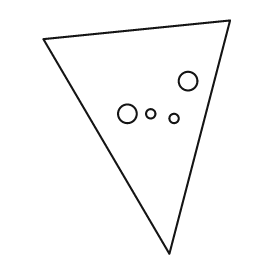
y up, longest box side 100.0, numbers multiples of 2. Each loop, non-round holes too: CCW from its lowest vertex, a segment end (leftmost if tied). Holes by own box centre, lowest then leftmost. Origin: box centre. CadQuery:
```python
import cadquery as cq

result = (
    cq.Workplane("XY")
    .moveTo(14.0, -50.0)
    .lineTo(40.0, 50.0)
    .lineTo(-40.0, 42.0)
    .close()
    .moveTo(16.0, 8.0)
    .circle(2.0)
    .moveTo(-4.0, 10.0)
    .circle(4.0)
    .moveTo(6.0, 10.0)
    .circle(2.0)
    .moveTo(22.0, 24.0)
    .circle(4.0)
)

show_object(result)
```